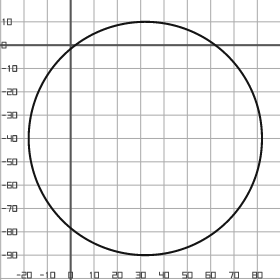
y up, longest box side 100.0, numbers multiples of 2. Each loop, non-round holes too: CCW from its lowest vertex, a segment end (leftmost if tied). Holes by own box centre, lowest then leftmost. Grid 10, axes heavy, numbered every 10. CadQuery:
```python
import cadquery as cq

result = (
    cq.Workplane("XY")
    .moveTo(32.0, -40.0)
    .circle(50.0)
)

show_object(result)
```